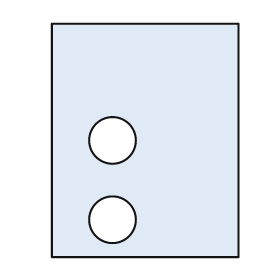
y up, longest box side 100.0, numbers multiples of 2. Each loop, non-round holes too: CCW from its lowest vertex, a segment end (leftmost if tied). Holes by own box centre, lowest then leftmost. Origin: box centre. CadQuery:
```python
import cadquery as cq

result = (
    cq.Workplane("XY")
    .moveTo(-40.0, -50.0)
    .lineTo(40.0, -50.0)
    .lineTo(40.0, 50.0)
    .lineTo(-40.0, 50.0)
    .close()
    .moveTo(-14.0, -34.0)
    .circle(10.0)
    .moveTo(-14.0, 0.0)
    .circle(10.0)
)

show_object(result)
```